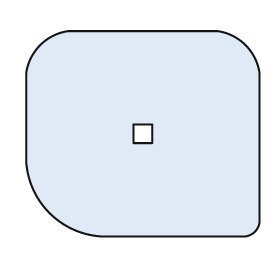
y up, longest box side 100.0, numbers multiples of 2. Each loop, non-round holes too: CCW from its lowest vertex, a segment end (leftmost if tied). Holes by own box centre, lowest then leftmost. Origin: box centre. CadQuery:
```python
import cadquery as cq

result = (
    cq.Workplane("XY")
    .moveTo(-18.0, -44.0)
    .lineTo(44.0, -44.0)
    .threePointArc((48.0, -42.0), (50.0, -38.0))
    .lineTo(50.0, 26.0)
    .threePointArc((44.0, 38.0), (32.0, 44.0))
    .lineTo(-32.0, 44.0)
    .threePointArc((-44.0, 38.0), (-50.0, 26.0))
    .lineTo(-50.0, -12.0)
    .threePointArc((-40.0, -34.0), (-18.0, -44.0))
    .close()
    .moveTo(-4.0, -4.0)
    .lineTo(4.0, -4.0)
    .lineTo(4.0, 4.0)
    .lineTo(-4.0, 4.0)
    .close()
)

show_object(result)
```